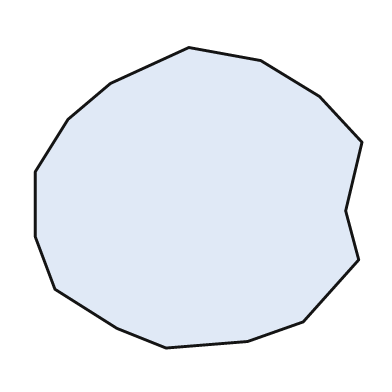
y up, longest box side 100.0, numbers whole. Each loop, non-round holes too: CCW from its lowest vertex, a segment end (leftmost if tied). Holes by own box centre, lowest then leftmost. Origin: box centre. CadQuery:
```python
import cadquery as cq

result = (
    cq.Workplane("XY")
    .moveTo(-10.0, -46.0)
    .lineTo(15.0, -44.0)
    .lineTo(32.0, -38.0)
    .lineTo(49.0, -19.0)
    .lineTo(45.0, -4.0)
    .lineTo(50.0, 17.0)
    .lineTo(37.0, 31.0)
    .lineTo(19.0, 42.0)
    .lineTo(-3.0, 46.0)
    .lineTo(-27.0, 35.0)
    .lineTo(-40.0, 24.0)
    .lineTo(-50.0, 8.0)
    .lineTo(-50.0, -12.0)
    .lineTo(-44.0, -28.0)
    .lineTo(-25.0, -40.0)
    .close()
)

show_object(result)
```